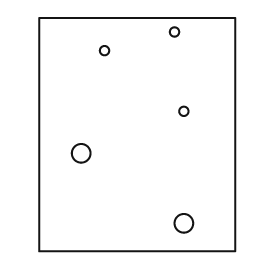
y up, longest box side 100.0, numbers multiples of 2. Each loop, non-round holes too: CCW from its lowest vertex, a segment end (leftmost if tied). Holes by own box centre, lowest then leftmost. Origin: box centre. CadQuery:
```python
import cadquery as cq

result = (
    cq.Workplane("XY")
    .moveTo(-42.0, -50.0)
    .lineTo(42.0, -50.0)
    .lineTo(42.0, 50.0)
    .lineTo(-42.0, 50.0)
    .close()
    .moveTo(20.0, -38.0)
    .circle(4.0)
    .moveTo(-24.0, -8.0)
    .circle(4.0)
    .moveTo(20.0, 10.0)
    .circle(2.0)
    .moveTo(-14.0, 36.0)
    .circle(2.0)
    .moveTo(16.0, 44.0)
    .circle(2.0)
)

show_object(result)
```